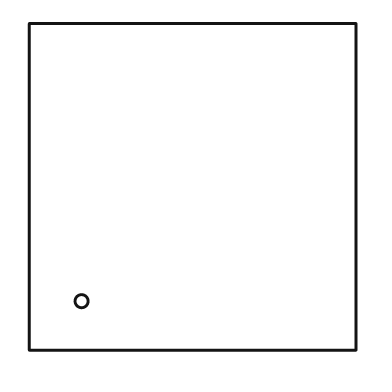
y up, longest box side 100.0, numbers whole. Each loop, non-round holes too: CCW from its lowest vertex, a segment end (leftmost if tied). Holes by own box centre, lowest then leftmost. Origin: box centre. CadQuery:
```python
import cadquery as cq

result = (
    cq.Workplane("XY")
    .moveTo(-50.0, -50.0)
    .lineTo(50.0, -50.0)
    .lineTo(50.0, 50.0)
    .lineTo(-50.0, 50.0)
    .close()
    .moveTo(-34.0, -35.0)
    .circle(2.0)
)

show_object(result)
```